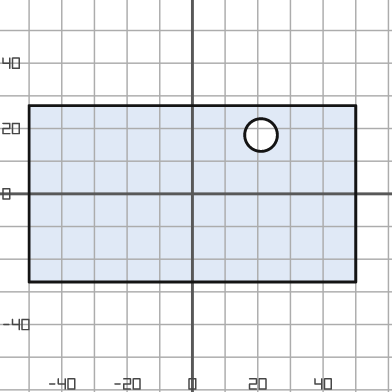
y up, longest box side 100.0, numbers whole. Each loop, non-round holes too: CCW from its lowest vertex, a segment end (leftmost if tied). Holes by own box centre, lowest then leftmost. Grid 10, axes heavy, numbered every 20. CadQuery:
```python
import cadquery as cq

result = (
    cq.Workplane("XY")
    .moveTo(-50.0, -27.0)
    .lineTo(50.0, -27.0)
    .lineTo(50.0, 27.0)
    .lineTo(-50.0, 27.0)
    .close()
    .moveTo(21.0, 18.0)
    .circle(5.0)
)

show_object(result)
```